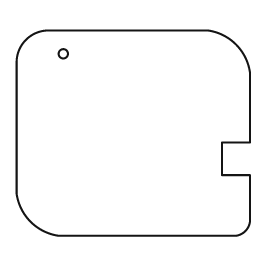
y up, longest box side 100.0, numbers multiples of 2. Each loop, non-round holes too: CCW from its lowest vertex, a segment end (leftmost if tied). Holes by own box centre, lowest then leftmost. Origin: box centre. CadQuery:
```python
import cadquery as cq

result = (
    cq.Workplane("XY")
    .moveTo(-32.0, -44.0)
    .lineTo(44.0, -44.0)
    .threePointArc((48.0, -42.0), (50.0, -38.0))
    .lineTo(50.0, -18.0)
    .lineTo(38.0, -18.0)
    .lineTo(38.0, -4.0)
    .lineTo(50.0, -4.0)
    .lineTo(50.0, 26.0)
    .threePointArc((44.0, 38.0), (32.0, 44.0))
    .lineTo(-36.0, 44.0)
    .threePointArc((-46.0, 40.0), (-50.0, 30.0))
    .lineTo(-50.0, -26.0)
    .threePointArc((-44.0, -38.0), (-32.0, -44.0))
    .close()
    .moveTo(-30.0, 34.0)
    .circle(2.0)
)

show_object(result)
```